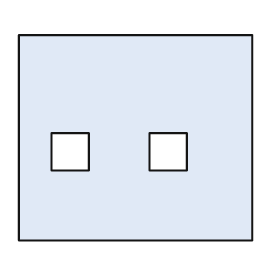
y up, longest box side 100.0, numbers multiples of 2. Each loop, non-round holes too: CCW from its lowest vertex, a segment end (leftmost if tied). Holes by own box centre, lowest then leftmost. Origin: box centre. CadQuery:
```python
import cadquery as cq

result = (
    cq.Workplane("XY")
    .moveTo(-50.0, -44.0)
    .lineTo(50.0, -44.0)
    .lineTo(50.0, 44.0)
    .lineTo(-50.0, 44.0)
    .close()
    .moveTo(-36.0, -14.0)
    .lineTo(-20.0, -14.0)
    .lineTo(-20.0, 2.0)
    .lineTo(-36.0, 2.0)
    .close()
    .moveTo(6.0, -14.0)
    .lineTo(22.0, -14.0)
    .lineTo(22.0, 2.0)
    .lineTo(6.0, 2.0)
    .close()
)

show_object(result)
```